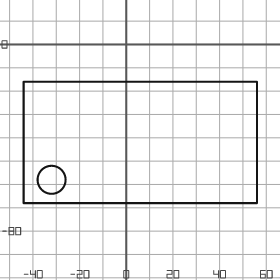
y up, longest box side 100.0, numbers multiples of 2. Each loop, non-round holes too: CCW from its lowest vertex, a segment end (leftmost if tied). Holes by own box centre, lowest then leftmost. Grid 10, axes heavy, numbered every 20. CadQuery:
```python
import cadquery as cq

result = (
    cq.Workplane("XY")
    .moveTo(-44.0, -68.0)
    .lineTo(56.0, -68.0)
    .lineTo(56.0, -16.0)
    .lineTo(-44.0, -16.0)
    .close()
    .moveTo(-32.0, -58.0)
    .circle(6.0)
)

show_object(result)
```